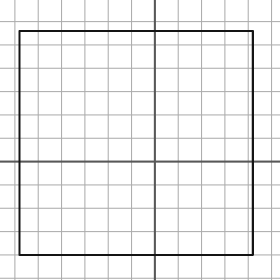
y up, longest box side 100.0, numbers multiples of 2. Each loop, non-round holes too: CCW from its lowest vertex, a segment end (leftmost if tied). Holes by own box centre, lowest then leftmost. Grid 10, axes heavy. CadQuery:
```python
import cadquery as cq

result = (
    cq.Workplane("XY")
    .moveTo(-58.0, -40.0)
    .lineTo(42.0, -40.0)
    .lineTo(42.0, 56.0)
    .lineTo(-58.0, 56.0)
    .close()
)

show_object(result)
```